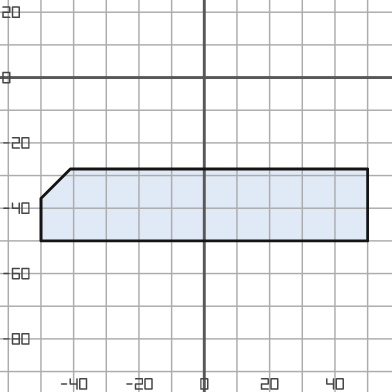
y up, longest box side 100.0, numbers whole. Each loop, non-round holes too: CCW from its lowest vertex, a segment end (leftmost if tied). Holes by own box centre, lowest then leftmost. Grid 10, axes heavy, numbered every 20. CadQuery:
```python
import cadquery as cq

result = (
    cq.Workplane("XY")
    .moveTo(-50.0, -50.0)
    .lineTo(50.0, -50.0)
    .lineTo(50.0, -28.0)
    .lineTo(-41.0, -28.0)
    .lineTo(-50.0, -37.0)
    .close()
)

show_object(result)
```